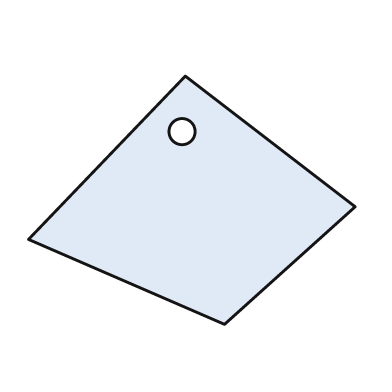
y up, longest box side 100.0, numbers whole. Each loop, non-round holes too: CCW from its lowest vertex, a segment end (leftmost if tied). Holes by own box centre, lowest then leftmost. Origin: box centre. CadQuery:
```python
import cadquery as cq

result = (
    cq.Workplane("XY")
    .moveTo(10.0, -38.0)
    .lineTo(50.0, -2.0)
    .lineTo(-2.0, 38.0)
    .lineTo(-50.0, -12.0)
    .close()
    .moveTo(-3.0, 21.0)
    .circle(4.0)
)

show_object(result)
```